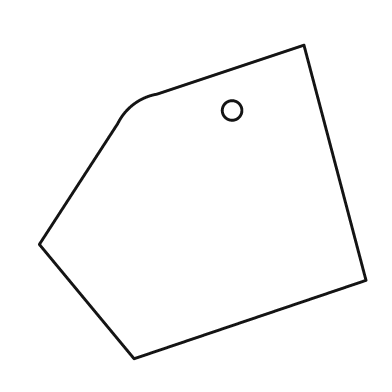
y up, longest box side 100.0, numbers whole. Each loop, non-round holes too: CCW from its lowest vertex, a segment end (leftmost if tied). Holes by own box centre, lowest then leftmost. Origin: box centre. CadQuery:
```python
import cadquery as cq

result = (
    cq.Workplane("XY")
    .moveTo(-21.0, -48.0)
    .lineTo(50.0, -24.0)
    .lineTo(31.0, 48.0)
    .lineTo(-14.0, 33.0)
    .threePointArc((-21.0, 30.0), (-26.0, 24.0))
    .lineTo(-50.0, -13.0)
    .close()
    .moveTo(9.0, 28.0)
    .circle(3.0)
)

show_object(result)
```